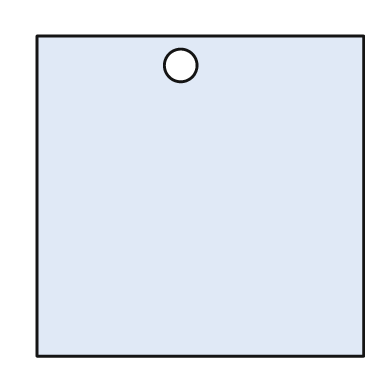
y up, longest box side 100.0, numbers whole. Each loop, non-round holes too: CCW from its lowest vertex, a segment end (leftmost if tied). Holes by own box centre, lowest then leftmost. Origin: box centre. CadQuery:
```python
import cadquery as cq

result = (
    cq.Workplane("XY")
    .moveTo(-50.0, -49.0)
    .lineTo(50.0, -49.0)
    .lineTo(50.0, 49.0)
    .lineTo(-50.0, 49.0)
    .close()
    .moveTo(-6.0, 40.0)
    .circle(5.0)
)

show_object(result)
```